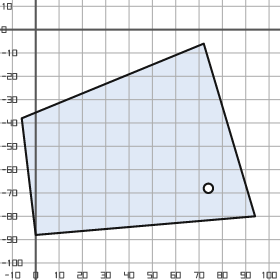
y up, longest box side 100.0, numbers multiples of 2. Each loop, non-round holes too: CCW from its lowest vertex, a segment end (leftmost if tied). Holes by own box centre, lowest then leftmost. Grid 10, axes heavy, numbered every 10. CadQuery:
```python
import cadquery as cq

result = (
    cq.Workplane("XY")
    .moveTo(0.0, -88.0)
    .lineTo(94.0, -80.0)
    .lineTo(72.0, -6.0)
    .lineTo(-6.0, -38.0)
    .close()
    .moveTo(74.0, -68.0)
    .circle(2.0)
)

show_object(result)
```